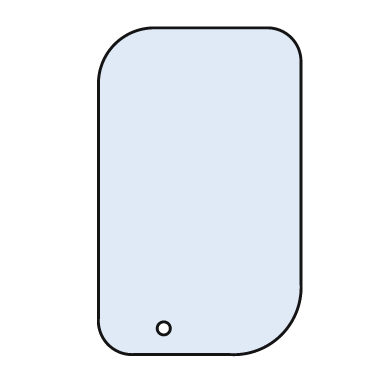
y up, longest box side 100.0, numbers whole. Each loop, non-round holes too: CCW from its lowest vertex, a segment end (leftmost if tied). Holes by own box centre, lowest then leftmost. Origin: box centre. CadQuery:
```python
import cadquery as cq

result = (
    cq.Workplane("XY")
    .moveTo(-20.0, -50.0)
    .lineTo(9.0, -50.0)
    .threePointArc((25.0, -44.0), (31.0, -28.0))
    .lineTo(31.0, 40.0)
    .threePointArc((28.0, 47.0), (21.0, 50.0))
    .lineTo(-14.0, 50.0)
    .threePointArc((-26.0, 45.0), (-31.0, 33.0))
    .lineTo(-31.0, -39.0)
    .threePointArc((-28.0, -47.0), (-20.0, -50.0))
    .close()
    .moveTo(-11.0, -42.0)
    .circle(2.0)
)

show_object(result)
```